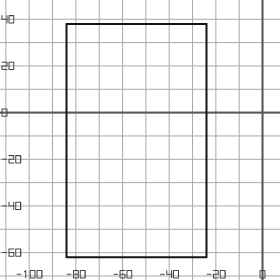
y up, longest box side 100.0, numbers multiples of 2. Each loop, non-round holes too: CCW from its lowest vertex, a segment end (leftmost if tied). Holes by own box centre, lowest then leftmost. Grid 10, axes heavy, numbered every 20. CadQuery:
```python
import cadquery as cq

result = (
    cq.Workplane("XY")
    .moveTo(-84.0, -62.0)
    .lineTo(-24.0, -62.0)
    .lineTo(-24.0, 38.0)
    .lineTo(-84.0, 38.0)
    .close()
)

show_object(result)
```